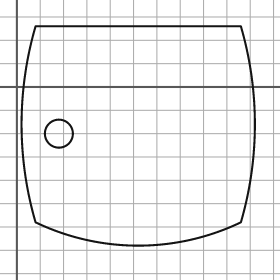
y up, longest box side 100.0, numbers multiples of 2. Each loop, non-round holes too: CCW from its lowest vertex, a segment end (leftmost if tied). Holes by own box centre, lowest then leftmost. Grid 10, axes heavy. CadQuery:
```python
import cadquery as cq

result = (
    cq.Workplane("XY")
    .moveTo(8.0, -58.0)
    .threePointArc((52.0, -68.0), (96.0, -58.0))
    .threePointArc((102.0, -16.0), (96.0, 26.0))
    .lineTo(8.0, 26.0)
    .threePointArc((2.0, -16.0), (8.0, -58.0))
    .close()
    .moveTo(18.0, -20.0)
    .circle(6.0)
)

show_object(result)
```